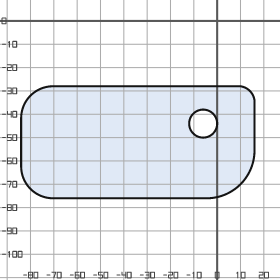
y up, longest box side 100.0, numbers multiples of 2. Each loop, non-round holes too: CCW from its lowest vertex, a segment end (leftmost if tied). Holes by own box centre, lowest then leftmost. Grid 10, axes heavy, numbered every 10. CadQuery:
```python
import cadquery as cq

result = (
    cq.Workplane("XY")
    .moveTo(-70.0, -76.0)
    .lineTo(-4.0, -76.0)
    .threePointArc((10.0, -70.0), (16.0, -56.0))
    .lineTo(16.0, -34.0)
    .threePointArc((14.0, -30.0), (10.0, -28.0))
    .lineTo(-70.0, -28.0)
    .threePointArc((-80.0, -32.0), (-84.0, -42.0))
    .lineTo(-84.0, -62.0)
    .threePointArc((-80.0, -72.0), (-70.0, -76.0))
    .close()
    .moveTo(-6.0, -44.0)
    .circle(6.0)
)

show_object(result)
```